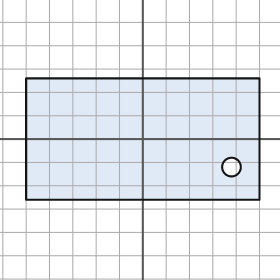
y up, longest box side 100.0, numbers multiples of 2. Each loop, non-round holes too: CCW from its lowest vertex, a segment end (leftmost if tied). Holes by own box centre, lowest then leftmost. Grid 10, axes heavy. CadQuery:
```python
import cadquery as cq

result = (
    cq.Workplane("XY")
    .moveTo(-50.0, -26.0)
    .lineTo(50.0, -26.0)
    .lineTo(50.0, 26.0)
    .lineTo(-50.0, 26.0)
    .close()
    .moveTo(38.0, -12.0)
    .circle(4.0)
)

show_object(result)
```